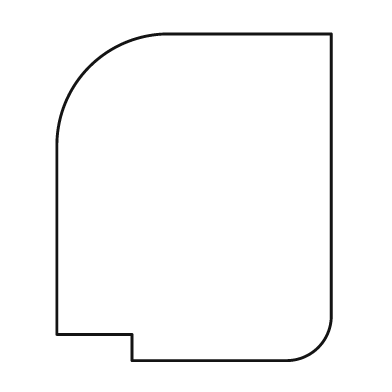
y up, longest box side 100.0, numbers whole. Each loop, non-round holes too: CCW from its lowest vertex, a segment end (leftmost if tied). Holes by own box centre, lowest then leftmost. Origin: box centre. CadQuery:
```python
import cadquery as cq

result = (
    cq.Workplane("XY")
    .moveTo(-19.0, -50.0)
    .lineTo(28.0, -50.0)
    .threePointArc((38.0, -46.0), (42.0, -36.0))
    .lineTo(42.0, 50.0)
    .lineTo(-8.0, 50.0)
    .threePointArc((-32.0, 40.0), (-42.0, 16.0))
    .lineTo(-42.0, -42.0)
    .lineTo(-19.0, -42.0)
    .close()
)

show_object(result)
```